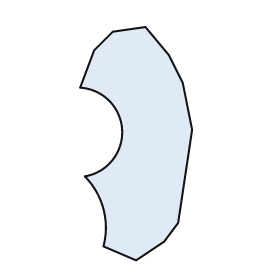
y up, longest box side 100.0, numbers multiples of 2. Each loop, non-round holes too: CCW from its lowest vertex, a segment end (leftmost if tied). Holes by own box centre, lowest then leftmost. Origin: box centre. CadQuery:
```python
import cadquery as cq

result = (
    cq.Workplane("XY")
    .moveTo(0.0, -50.0)
    .lineTo(12.0, -42.0)
    .lineTo(18.0, -34.0)
    .lineTo(24.0, 6.0)
    .lineTo(20.0, 26.0)
    .lineTo(14.0, 38.0)
    .lineTo(4.0, 50.0)
    .lineTo(-10.0, 48.0)
    .lineTo(-18.0, 40.0)
    .lineTo(-24.0, 24.0)
    .threePointArc((-6.0, 6.0), (-22.0, -14.0))
    .threePointArc((-14.0, -28.0), (-14.0, -44.0))
    .close()
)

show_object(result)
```